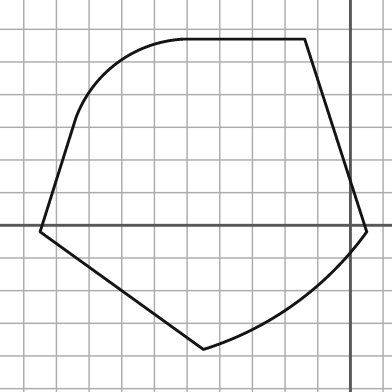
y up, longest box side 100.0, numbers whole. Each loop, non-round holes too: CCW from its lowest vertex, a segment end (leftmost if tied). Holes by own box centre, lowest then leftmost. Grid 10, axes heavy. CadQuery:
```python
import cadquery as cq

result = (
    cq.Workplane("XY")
    .moveTo(-45.0, -38.0)
    .threePointArc((-17.0, -24.0), (5.0, -2.0))
    .lineTo(-14.0, 57.0)
    .lineTo(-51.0, 57.0)
    .threePointArc((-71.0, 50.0), (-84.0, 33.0))
    .lineTo(-95.0, -2.0)
    .close()
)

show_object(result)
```